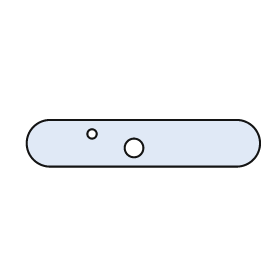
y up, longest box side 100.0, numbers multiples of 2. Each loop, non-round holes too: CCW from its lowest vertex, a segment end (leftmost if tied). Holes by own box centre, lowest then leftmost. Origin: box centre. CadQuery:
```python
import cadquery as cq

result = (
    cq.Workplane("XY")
    .moveTo(-40.0, -10.0)
    .lineTo(40.0, -10.0)
    .threePointArc((50.0, 0.0), (40.0, 10.0))
    .lineTo(-40.0, 10.0)
    .threePointArc((-50.0, 0.0), (-40.0, -10.0))
    .close()
    .moveTo(-4.0, -2.0)
    .circle(4.0)
    .moveTo(-22.0, 4.0)
    .circle(2.0)
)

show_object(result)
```